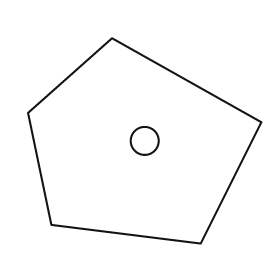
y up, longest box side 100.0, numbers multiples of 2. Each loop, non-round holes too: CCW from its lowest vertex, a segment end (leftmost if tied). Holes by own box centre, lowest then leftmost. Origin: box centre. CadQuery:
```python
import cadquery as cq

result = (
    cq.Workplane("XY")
    .moveTo(24.0, -44.0)
    .lineTo(50.0, 8.0)
    .lineTo(-14.0, 44.0)
    .lineTo(-50.0, 12.0)
    .lineTo(-40.0, -36.0)
    .close()
    .moveTo(0.0, 0.0)
    .circle(6.0)
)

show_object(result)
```